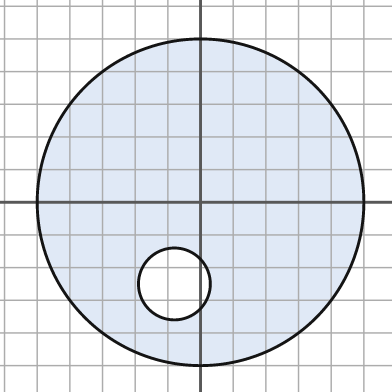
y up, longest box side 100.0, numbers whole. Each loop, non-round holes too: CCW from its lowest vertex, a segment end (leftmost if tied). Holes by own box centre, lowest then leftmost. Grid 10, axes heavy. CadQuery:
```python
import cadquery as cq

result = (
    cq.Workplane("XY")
    .moveTo(0.0, 0.0)
    .circle(50.0)
    .moveTo(-8.0, -25.0)
    .circle(11.0)
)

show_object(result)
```